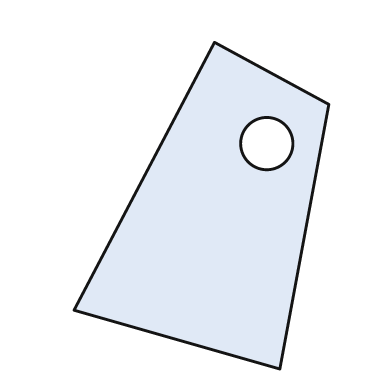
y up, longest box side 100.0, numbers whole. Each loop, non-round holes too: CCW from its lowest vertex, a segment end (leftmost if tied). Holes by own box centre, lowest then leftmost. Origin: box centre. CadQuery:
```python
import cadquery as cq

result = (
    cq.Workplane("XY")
    .moveTo(24.0, -50.0)
    .lineTo(39.0, 31.0)
    .lineTo(4.0, 50.0)
    .lineTo(-39.0, -32.0)
    .close()
    .moveTo(20.0, 19.0)
    .circle(8.0)
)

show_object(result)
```